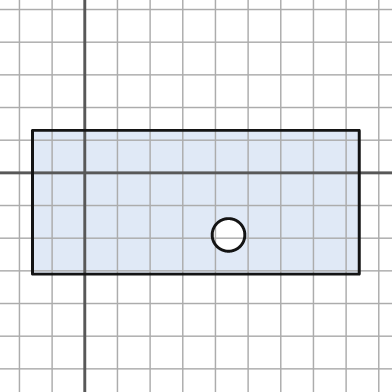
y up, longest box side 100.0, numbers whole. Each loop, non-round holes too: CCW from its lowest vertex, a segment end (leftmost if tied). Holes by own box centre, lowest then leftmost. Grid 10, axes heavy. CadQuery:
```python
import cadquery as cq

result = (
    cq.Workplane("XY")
    .moveTo(-16.0, -31.0)
    .lineTo(84.0, -31.0)
    .lineTo(84.0, 13.0)
    .lineTo(-16.0, 13.0)
    .close()
    .moveTo(44.0, -19.0)
    .circle(5.0)
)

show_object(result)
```